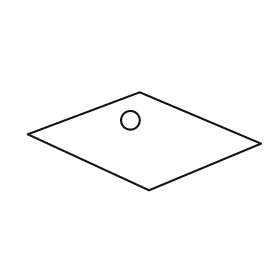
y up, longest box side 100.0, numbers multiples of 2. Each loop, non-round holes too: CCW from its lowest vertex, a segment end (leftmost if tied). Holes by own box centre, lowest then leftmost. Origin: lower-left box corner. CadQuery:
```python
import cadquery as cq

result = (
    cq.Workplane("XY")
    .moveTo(52.0, 0.0)
    .lineTo(100.0, 20.0)
    .lineTo(48.0, 42.0)
    .lineTo(0.0, 24.0)
    .close()
    .moveTo(44.0, 30.0)
    .circle(4.0)
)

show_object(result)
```